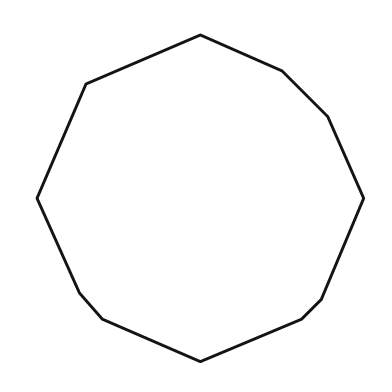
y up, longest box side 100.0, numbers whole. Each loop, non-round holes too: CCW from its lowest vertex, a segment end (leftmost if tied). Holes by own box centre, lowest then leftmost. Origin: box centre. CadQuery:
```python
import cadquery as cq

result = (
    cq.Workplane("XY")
    .moveTo(0.0, -50.0)
    .lineTo(31.0, -37.0)
    .lineTo(37.0, -31.0)
    .lineTo(50.0, 0.0)
    .lineTo(39.0, 25.0)
    .lineTo(25.0, 39.0)
    .lineTo(0.0, 50.0)
    .lineTo(-35.0, 35.0)
    .lineTo(-50.0, 0.0)
    .lineTo(-37.0, -29.0)
    .lineTo(-30.0, -37.0)
    .close()
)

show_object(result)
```